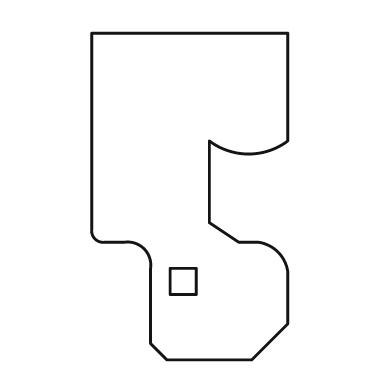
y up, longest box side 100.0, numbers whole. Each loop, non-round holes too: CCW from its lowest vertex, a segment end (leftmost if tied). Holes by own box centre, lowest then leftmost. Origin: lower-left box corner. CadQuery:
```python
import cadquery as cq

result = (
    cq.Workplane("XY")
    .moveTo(23.0, 0.0)
    .lineTo(49.0, 0.0)
    .lineTo(60.0, 11.0)
    .lineTo(60.0, 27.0)
    .threePointArc((57.0, 33.0), (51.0, 36.0))
    .lineTo(45.0, 36.0)
    .lineTo(36.0, 42.0)
    .lineTo(36.0, 67.0)
    .threePointArc((48.0, 63.0), (60.0, 67.0))
    .lineTo(60.0, 100.0)
    .lineTo(0.0, 100.0)
    .lineTo(0.0, 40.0)
    .threePointArc((1.0, 37.0), (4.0, 36.0))
    .lineTo(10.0, 36.0)
    .threePointArc((16.0, 34.0), (18.0, 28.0))
    .lineTo(18.0, 5.0)
    .close()
    .moveTo(24.0, 20.0)
    .lineTo(32.0, 20.0)
    .lineTo(32.0, 28.0)
    .lineTo(24.0, 28.0)
    .close()
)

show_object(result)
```